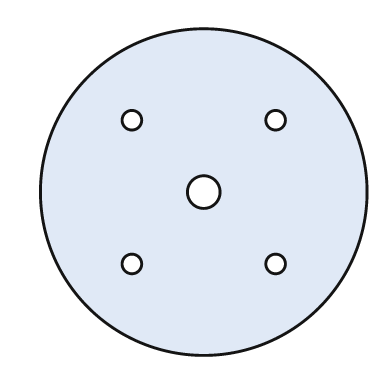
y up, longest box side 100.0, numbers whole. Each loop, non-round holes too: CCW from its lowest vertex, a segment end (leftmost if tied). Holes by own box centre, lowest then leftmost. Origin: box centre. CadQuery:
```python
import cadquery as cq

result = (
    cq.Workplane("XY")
    .moveTo(0.0, 0.0)
    .circle(50.0)
    .moveTo(-22.0, -22.0)
    .circle(3.0)
    .moveTo(22.0, -22.0)
    .circle(3.0)
    .moveTo(0.0, 0.0)
    .circle(5.0)
    .moveTo(-22.0, 22.0)
    .circle(3.0)
    .moveTo(22.0, 22.0)
    .circle(3.0)
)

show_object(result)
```